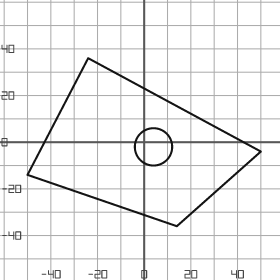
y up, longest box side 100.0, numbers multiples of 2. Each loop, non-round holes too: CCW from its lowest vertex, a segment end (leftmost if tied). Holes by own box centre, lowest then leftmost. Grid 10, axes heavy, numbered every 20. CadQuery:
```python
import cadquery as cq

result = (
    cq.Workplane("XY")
    .moveTo(14.0, -36.0)
    .lineTo(50.0, -4.0)
    .lineTo(-24.0, 36.0)
    .lineTo(-50.0, -14.0)
    .close()
    .moveTo(4.0, -2.0)
    .circle(8.0)
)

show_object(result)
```